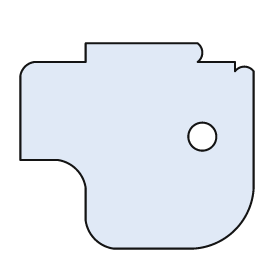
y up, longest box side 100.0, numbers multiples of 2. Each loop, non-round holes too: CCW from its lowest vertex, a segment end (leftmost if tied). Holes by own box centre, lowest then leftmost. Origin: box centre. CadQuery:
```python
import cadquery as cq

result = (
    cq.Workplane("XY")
    .moveTo(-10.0, -44.0)
    .lineTo(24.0, -44.0)
    .threePointArc((42.0, -36.0), (50.0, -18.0))
    .lineTo(50.0, 32.0)
    .threePointArc((46.0, 34.0), (42.0, 32.0))
    .lineTo(42.0, 36.0)
    .lineTo(26.0, 36.0)
    .threePointArc((28.0, 40.0), (26.0, 44.0))
    .lineTo(-22.0, 44.0)
    .lineTo(-22.0, 36.0)
    .lineTo(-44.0, 36.0)
    .threePointArc((-48.0, 34.0), (-50.0, 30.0))
    .lineTo(-50.0, -6.0)
    .lineTo(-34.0, -6.0)
    .threePointArc((-26.0, -10.0), (-22.0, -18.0))
    .lineTo(-22.0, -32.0)
    .threePointArc((-18.0, -40.0), (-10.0, -44.0))
    .close()
    .moveTo(28.0, 4.0)
    .circle(6.0)
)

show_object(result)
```